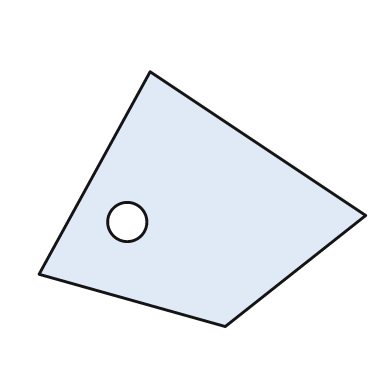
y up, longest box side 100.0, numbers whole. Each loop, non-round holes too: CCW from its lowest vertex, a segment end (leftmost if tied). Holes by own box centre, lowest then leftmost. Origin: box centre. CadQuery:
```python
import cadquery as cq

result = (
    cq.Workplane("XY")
    .moveTo(7.0, -39.0)
    .lineTo(50.0, -5.0)
    .lineTo(-16.0, 39.0)
    .lineTo(-50.0, -23.0)
    .close()
    .moveTo(-23.0, -7.0)
    .circle(6.0)
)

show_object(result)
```